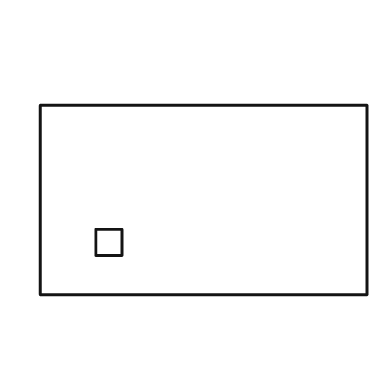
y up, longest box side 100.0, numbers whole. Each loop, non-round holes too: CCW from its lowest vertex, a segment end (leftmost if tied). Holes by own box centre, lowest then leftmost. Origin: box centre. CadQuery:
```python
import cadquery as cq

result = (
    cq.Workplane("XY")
    .moveTo(-50.0, -29.0)
    .lineTo(50.0, -29.0)
    .lineTo(50.0, 29.0)
    .lineTo(-50.0, 29.0)
    .close()
    .moveTo(-33.0, -17.0)
    .lineTo(-25.0, -17.0)
    .lineTo(-25.0, -9.0)
    .lineTo(-33.0, -9.0)
    .close()
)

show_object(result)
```